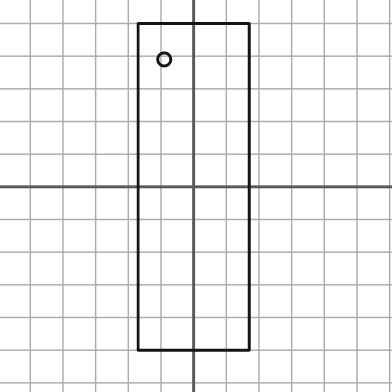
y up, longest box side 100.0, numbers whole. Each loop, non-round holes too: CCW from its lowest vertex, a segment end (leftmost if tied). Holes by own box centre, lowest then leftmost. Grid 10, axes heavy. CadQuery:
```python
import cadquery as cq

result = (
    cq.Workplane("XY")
    .moveTo(-17.0, -50.0)
    .lineTo(17.0, -50.0)
    .lineTo(17.0, 50.0)
    .lineTo(-17.0, 50.0)
    .close()
    .moveTo(-9.0, 39.0)
    .circle(2.0)
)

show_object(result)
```